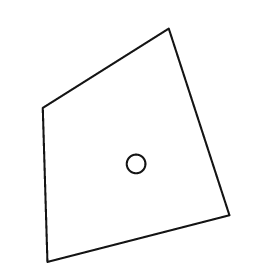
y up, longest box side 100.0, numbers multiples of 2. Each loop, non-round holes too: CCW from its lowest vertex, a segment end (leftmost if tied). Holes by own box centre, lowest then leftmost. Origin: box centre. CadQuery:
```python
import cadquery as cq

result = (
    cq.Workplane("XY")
    .moveTo(-38.0, -50.0)
    .lineTo(40.0, -30.0)
    .lineTo(14.0, 50.0)
    .lineTo(-40.0, 16.0)
    .close()
    .moveTo(0.0, -8.0)
    .circle(4.0)
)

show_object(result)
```